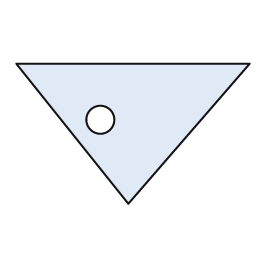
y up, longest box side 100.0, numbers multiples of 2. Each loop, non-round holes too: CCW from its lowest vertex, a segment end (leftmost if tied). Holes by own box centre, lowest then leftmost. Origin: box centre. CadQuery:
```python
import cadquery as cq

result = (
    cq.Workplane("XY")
    .moveTo(-2.0, -30.0)
    .lineTo(50.0, 30.0)
    .lineTo(-50.0, 30.0)
    .close()
    .moveTo(-14.0, 6.0)
    .circle(6.0)
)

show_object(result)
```